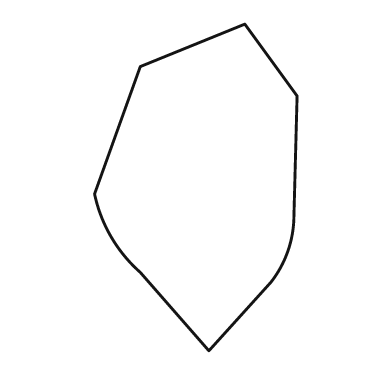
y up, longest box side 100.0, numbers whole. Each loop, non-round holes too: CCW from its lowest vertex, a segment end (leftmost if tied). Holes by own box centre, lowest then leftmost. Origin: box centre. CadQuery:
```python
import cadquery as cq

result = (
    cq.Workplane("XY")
    .moveTo(4.0, -50.0)
    .lineTo(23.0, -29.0)
    .threePointArc((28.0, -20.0), (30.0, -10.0))
    .lineTo(31.0, 28.0)
    .lineTo(15.0, 50.0)
    .lineTo(-17.0, 37.0)
    .lineTo(-31.0, -2.0)
    .threePointArc((-26.0, -15.0), (-17.0, -26.0))
    .close()
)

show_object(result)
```